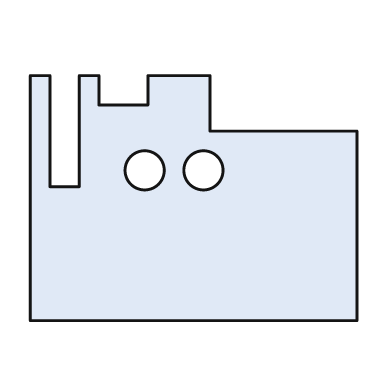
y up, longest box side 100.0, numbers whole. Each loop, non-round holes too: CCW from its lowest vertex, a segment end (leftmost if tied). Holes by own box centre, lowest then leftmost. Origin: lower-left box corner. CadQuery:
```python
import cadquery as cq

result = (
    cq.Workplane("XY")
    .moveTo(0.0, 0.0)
    .lineTo(100.0, 0.0)
    .lineTo(100.0, 58.0)
    .lineTo(55.0, 58.0)
    .lineTo(55.0, 75.0)
    .lineTo(36.0, 75.0)
    .lineTo(36.0, 66.0)
    .lineTo(21.0, 66.0)
    .lineTo(21.0, 75.0)
    .lineTo(15.0, 75.0)
    .lineTo(15.0, 41.0)
    .lineTo(6.0, 41.0)
    .lineTo(6.0, 75.0)
    .lineTo(0.0, 75.0)
    .close()
    .moveTo(35.0, 46.0)
    .circle(6.0)
    .moveTo(53.0, 46.0)
    .circle(6.0)
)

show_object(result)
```